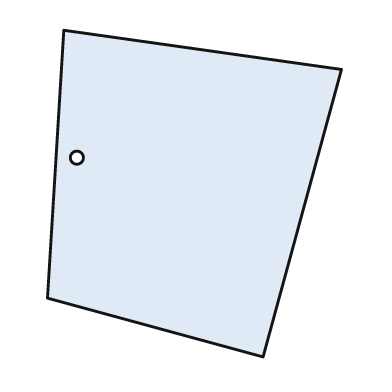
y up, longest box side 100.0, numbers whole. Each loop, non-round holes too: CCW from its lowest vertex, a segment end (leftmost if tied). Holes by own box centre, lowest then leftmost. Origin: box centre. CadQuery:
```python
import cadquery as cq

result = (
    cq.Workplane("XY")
    .moveTo(21.0, -50.0)
    .lineTo(45.0, 38.0)
    .lineTo(-40.0, 50.0)
    .lineTo(-45.0, -32.0)
    .close()
    .moveTo(-36.0, 11.0)
    .circle(2.0)
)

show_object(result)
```